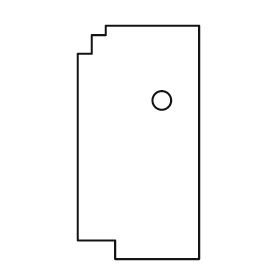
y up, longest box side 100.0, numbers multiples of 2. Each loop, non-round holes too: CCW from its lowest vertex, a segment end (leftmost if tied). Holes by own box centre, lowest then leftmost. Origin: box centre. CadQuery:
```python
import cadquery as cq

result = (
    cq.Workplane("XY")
    .moveTo(-10.0, -50.0)
    .lineTo(26.0, -50.0)
    .lineTo(26.0, 50.0)
    .lineTo(-14.0, 50.0)
    .lineTo(-14.0, 46.0)
    .lineTo(-20.0, 46.0)
    .lineTo(-20.0, 38.0)
    .lineTo(-26.0, 38.0)
    .lineTo(-26.0, -42.0)
    .lineTo(-10.0, -42.0)
    .close()
    .moveTo(10.0, 18.0)
    .circle(4.0)
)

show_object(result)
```